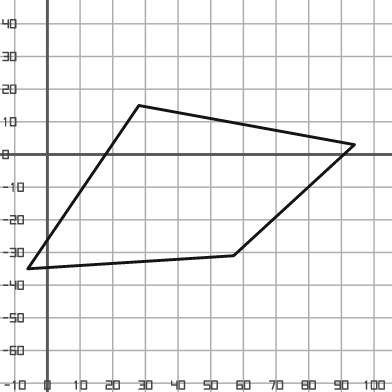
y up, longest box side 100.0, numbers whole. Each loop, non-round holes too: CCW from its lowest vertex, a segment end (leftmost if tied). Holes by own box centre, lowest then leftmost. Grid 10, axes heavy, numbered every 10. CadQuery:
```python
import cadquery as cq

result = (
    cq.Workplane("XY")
    .moveTo(-6.0, -35.0)
    .lineTo(57.0, -31.0)
    .lineTo(94.0, 3.0)
    .lineTo(28.0, 15.0)
    .close()
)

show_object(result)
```